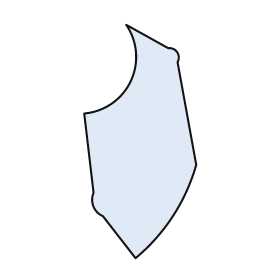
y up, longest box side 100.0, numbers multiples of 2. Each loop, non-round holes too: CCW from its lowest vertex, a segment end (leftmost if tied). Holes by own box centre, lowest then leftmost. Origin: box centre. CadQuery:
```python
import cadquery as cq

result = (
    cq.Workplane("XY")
    .moveTo(-2.0, -50.0)
    .threePointArc((14.0, -32.0), (24.0, -10.0))
    .lineTo(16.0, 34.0)
    .threePointArc((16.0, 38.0), (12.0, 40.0))
    .lineTo(-6.0, 50.0)
    .threePointArc((-4.0, 26.0), (-24.0, 12.0))
    .lineTo(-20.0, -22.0)
    .threePointArc((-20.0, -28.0), (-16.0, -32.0))
    .close()
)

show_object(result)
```